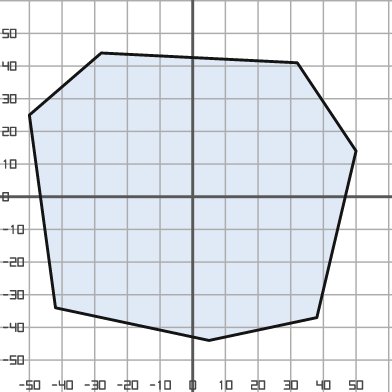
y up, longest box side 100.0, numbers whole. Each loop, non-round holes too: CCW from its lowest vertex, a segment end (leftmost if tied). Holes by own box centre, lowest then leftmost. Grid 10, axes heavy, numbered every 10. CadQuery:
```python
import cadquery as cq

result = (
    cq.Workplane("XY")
    .moveTo(5.0, -44.0)
    .lineTo(38.0, -37.0)
    .lineTo(50.0, 14.0)
    .lineTo(32.0, 41.0)
    .lineTo(-28.0, 44.0)
    .lineTo(-50.0, 25.0)
    .lineTo(-42.0, -34.0)
    .close()
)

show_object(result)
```